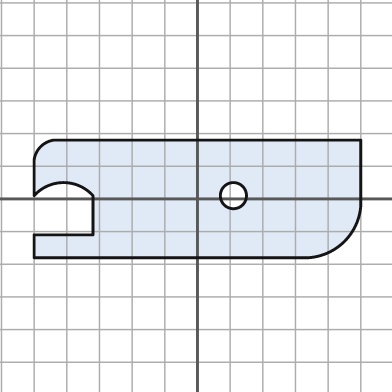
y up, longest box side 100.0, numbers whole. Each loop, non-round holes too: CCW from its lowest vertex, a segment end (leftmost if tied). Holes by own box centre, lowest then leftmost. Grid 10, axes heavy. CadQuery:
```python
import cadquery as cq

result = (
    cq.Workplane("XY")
    .moveTo(-50.0, -18.0)
    .lineTo(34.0, -18.0)
    .threePointArc((45.0, -13.0), (50.0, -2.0))
    .lineTo(50.0, 18.0)
    .lineTo(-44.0, 18.0)
    .threePointArc((-48.0, 16.0), (-50.0, 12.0))
    .lineTo(-50.0, 1.0)
    .threePointArc((-41.0, 5.0), (-32.0, 1.0))
    .lineTo(-32.0, -11.0)
    .lineTo(-50.0, -11.0)
    .close()
    .moveTo(11.0, 1.0)
    .circle(4.0)
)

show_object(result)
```